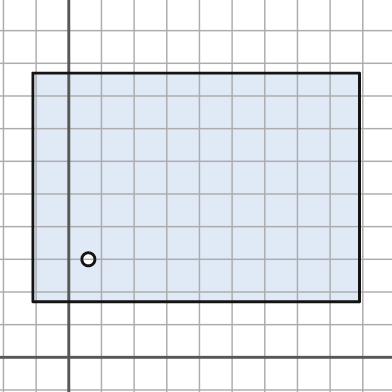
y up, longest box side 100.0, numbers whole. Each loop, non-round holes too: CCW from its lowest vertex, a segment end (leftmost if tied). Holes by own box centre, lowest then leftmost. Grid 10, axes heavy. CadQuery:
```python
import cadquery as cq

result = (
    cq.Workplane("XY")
    .moveTo(-11.0, 17.0)
    .lineTo(89.0, 17.0)
    .lineTo(89.0, 87.0)
    .lineTo(-11.0, 87.0)
    .close()
    .moveTo(6.0, 30.0)
    .circle(2.0)
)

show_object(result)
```